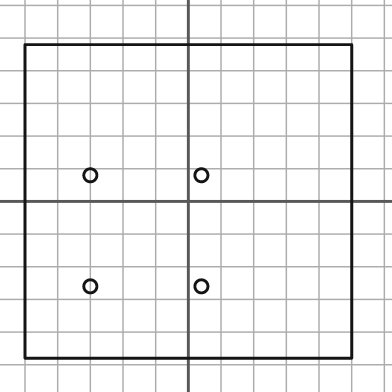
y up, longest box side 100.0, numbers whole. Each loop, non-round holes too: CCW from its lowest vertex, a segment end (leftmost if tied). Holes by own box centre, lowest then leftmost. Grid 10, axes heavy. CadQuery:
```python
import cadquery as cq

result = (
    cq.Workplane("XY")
    .moveTo(-50.0, -48.0)
    .lineTo(50.0, -48.0)
    .lineTo(50.0, 48.0)
    .lineTo(-50.0, 48.0)
    .close()
    .moveTo(-30.0, -26.0)
    .circle(2.0)
    .moveTo(4.0, -26.0)
    .circle(2.0)
    .moveTo(-30.0, 8.0)
    .circle(2.0)
    .moveTo(4.0, 8.0)
    .circle(2.0)
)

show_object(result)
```